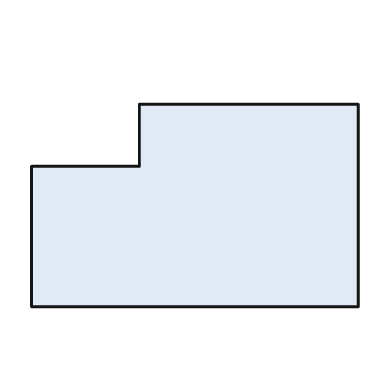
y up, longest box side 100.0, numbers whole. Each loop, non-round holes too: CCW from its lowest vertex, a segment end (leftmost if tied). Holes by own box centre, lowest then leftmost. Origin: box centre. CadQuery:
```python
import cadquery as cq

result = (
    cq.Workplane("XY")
    .moveTo(-50.0, -31.0)
    .lineTo(50.0, -31.0)
    .lineTo(50.0, 31.0)
    .lineTo(-17.0, 31.0)
    .lineTo(-17.0, 12.0)
    .lineTo(-50.0, 12.0)
    .close()
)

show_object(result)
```